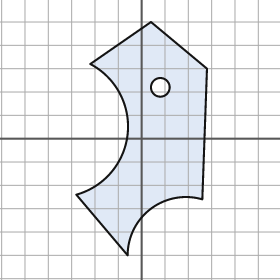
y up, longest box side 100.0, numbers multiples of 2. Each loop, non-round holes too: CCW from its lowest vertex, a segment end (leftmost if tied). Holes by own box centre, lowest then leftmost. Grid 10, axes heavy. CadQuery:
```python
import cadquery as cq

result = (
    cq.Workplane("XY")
    .moveTo(-6.0, -50.0)
    .threePointArc((4.0, -30.0), (26.0, -26.0))
    .lineTo(28.0, 30.0)
    .lineTo(4.0, 50.0)
    .lineTo(-22.0, 32.0)
    .threePointArc((-6.0, 2.0), (-28.0, -24.0))
    .close()
    .moveTo(8.0, 22.0)
    .circle(4.0)
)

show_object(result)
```